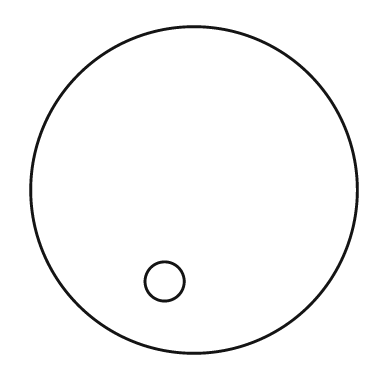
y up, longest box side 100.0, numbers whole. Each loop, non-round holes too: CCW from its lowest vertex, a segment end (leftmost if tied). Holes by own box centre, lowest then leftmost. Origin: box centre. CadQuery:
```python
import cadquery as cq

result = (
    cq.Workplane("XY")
    .moveTo(0.0, 0.0)
    .circle(50.0)
    .moveTo(-9.0, -28.0)
    .circle(6.0)
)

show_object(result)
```